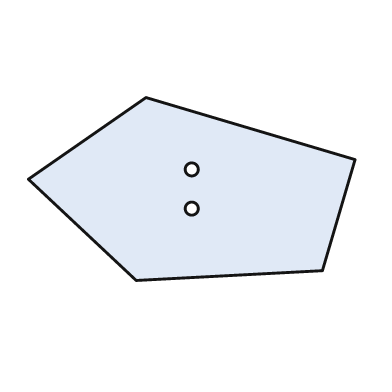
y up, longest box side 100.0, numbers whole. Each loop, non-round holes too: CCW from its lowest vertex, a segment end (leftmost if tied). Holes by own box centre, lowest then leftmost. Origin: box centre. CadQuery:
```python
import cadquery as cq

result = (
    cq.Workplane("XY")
    .moveTo(-17.0, -28.0)
    .lineTo(40.0, -25.0)
    .lineTo(50.0, 9.0)
    .lineTo(-14.0, 28.0)
    .lineTo(-50.0, 3.0)
    .close()
    .moveTo(0.0, -6.0)
    .circle(2.0)
    .moveTo(0.0, 6.0)
    .circle(2.0)
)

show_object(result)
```